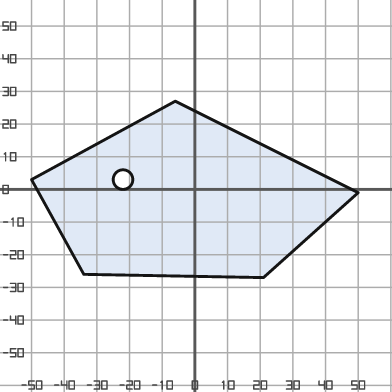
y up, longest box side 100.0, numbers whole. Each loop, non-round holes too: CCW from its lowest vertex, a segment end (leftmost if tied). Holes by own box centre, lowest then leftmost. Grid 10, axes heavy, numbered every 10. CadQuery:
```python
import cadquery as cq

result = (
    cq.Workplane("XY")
    .moveTo(21.0, -27.0)
    .lineTo(50.0, -1.0)
    .lineTo(-6.0, 27.0)
    .lineTo(-50.0, 3.0)
    .lineTo(-34.0, -26.0)
    .close()
    .moveTo(-22.0, 3.0)
    .circle(3.0)
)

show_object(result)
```